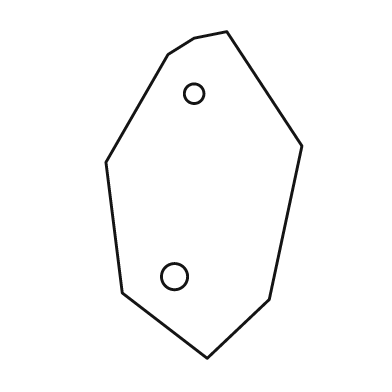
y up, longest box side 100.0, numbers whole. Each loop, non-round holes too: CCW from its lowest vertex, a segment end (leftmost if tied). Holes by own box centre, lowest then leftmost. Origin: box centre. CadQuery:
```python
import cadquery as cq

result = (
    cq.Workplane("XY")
    .moveTo(1.0, -50.0)
    .lineTo(20.0, -32.0)
    .lineTo(30.0, 15.0)
    .lineTo(7.0, 50.0)
    .lineTo(-3.0, 48.0)
    .lineTo(-11.0, 43.0)
    .lineTo(-30.0, 10.0)
    .lineTo(-25.0, -30.0)
    .close()
    .moveTo(-9.0, -25.0)
    .circle(4.0)
    .moveTo(-3.0, 31.0)
    .circle(3.0)
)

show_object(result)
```